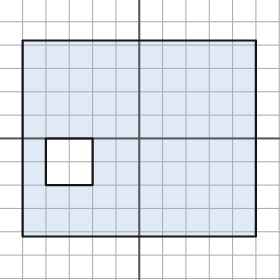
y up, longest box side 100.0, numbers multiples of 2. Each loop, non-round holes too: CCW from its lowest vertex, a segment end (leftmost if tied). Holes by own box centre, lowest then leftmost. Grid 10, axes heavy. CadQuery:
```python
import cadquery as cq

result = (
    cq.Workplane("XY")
    .moveTo(-50.0, -42.0)
    .lineTo(50.0, -42.0)
    .lineTo(50.0, 42.0)
    .lineTo(-50.0, 42.0)
    .close()
    .moveTo(-40.0, -20.0)
    .lineTo(-20.0, -20.0)
    .lineTo(-20.0, 0.0)
    .lineTo(-40.0, 0.0)
    .close()
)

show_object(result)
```